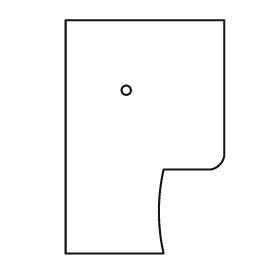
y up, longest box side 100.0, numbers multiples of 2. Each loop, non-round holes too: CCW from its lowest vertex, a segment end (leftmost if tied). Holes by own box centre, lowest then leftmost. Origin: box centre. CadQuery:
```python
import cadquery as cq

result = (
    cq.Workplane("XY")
    .moveTo(-34.0, -50.0)
    .lineTo(8.0, -50.0)
    .threePointArc((6.0, -32.0), (8.0, -14.0))
    .lineTo(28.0, -14.0)
    .threePointArc((32.0, -12.0), (34.0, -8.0))
    .lineTo(34.0, 50.0)
    .lineTo(-34.0, 50.0)
    .close()
    .moveTo(-8.0, 20.0)
    .circle(2.0)
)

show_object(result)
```